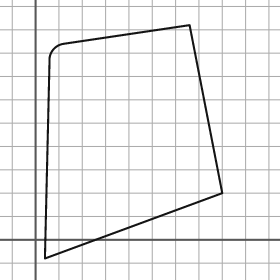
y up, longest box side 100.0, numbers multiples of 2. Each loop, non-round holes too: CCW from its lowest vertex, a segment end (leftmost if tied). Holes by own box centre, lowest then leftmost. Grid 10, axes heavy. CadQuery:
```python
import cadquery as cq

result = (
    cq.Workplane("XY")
    .moveTo(4.0, -8.0)
    .lineTo(80.0, 20.0)
    .lineTo(66.0, 92.0)
    .lineTo(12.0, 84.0)
    .threePointArc((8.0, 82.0), (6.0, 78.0))
    .close()
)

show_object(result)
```